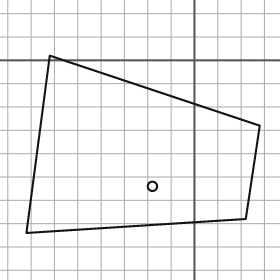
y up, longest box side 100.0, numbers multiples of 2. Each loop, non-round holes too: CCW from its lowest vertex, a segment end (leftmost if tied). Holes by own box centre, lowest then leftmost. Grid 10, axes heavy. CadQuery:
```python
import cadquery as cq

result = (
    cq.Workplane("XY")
    .moveTo(-72.0, -74.0)
    .lineTo(22.0, -68.0)
    .lineTo(28.0, -28.0)
    .lineTo(-62.0, 2.0)
    .close()
    .moveTo(-18.0, -54.0)
    .circle(2.0)
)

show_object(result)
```